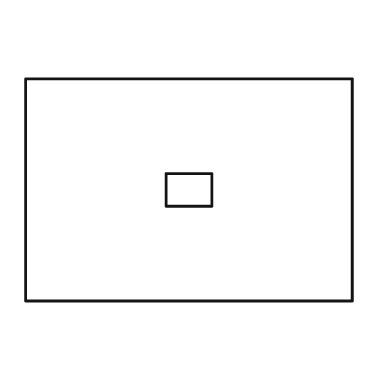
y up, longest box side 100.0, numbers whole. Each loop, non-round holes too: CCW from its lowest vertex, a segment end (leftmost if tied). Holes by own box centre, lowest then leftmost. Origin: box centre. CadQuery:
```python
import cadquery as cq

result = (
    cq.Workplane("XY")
    .moveTo(-50.0, -34.0)
    .lineTo(50.0, -34.0)
    .lineTo(50.0, 34.0)
    .lineTo(-50.0, 34.0)
    .close()
    .moveTo(-7.0, -5.0)
    .lineTo(7.0, -5.0)
    .lineTo(7.0, 5.0)
    .lineTo(-7.0, 5.0)
    .close()
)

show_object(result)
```